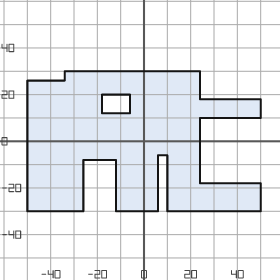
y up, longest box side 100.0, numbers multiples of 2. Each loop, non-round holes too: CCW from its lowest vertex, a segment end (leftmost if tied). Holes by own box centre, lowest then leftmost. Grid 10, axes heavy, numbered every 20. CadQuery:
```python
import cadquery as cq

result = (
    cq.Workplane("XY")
    .moveTo(-50.0, -30.0)
    .lineTo(-26.0, -30.0)
    .lineTo(-26.0, -8.0)
    .lineTo(-12.0, -8.0)
    .lineTo(-12.0, -30.0)
    .lineTo(6.0, -30.0)
    .lineTo(6.0, -6.0)
    .lineTo(10.0, -6.0)
    .lineTo(10.0, -30.0)
    .lineTo(50.0, -30.0)
    .lineTo(50.0, -18.0)
    .lineTo(24.0, -18.0)
    .lineTo(24.0, 10.0)
    .lineTo(50.0, 10.0)
    .lineTo(50.0, 18.0)
    .lineTo(24.0, 18.0)
    .lineTo(24.0, 30.0)
    .lineTo(-34.0, 30.0)
    .lineTo(-34.0, 26.0)
    .lineTo(-50.0, 26.0)
    .close()
    .moveTo(-18.0, 12.0)
    .lineTo(-6.0, 12.0)
    .lineTo(-6.0, 20.0)
    .lineTo(-18.0, 20.0)
    .close()
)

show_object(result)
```